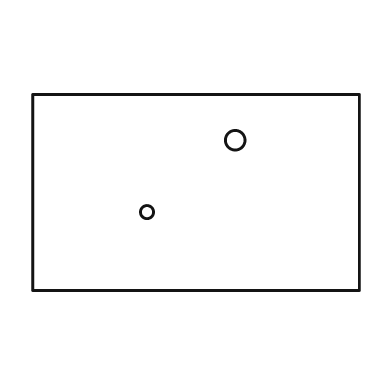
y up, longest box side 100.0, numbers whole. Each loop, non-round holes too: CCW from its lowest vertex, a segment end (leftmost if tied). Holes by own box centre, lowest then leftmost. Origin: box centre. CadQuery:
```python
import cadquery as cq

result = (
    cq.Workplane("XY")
    .moveTo(-50.0, -30.0)
    .lineTo(50.0, -30.0)
    .lineTo(50.0, 30.0)
    .lineTo(-50.0, 30.0)
    .close()
    .moveTo(-15.0, -6.0)
    .circle(2.0)
    .moveTo(12.0, 16.0)
    .circle(3.0)
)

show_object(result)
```